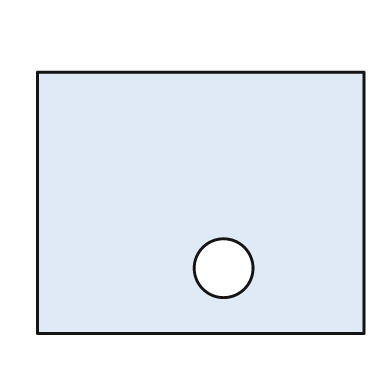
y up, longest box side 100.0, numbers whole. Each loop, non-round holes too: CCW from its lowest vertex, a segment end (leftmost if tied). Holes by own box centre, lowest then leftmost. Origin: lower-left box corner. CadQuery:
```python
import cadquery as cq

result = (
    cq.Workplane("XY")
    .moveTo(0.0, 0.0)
    .lineTo(100.0, 0.0)
    .lineTo(100.0, 80.0)
    .lineTo(0.0, 80.0)
    .close()
    .moveTo(57.0, 20.0)
    .circle(9.0)
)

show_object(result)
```